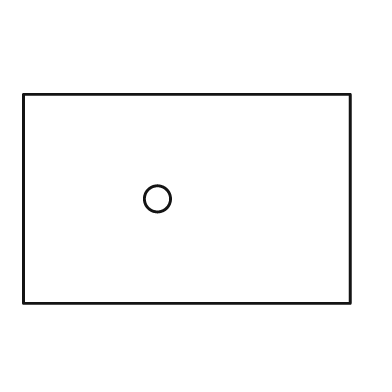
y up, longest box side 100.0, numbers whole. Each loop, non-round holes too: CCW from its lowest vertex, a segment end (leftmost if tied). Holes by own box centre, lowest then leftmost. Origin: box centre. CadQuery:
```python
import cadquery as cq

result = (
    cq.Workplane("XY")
    .moveTo(-50.0, -32.0)
    .lineTo(50.0, -32.0)
    .lineTo(50.0, 32.0)
    .lineTo(-50.0, 32.0)
    .close()
    .moveTo(-9.0, 0.0)
    .circle(4.0)
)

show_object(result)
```